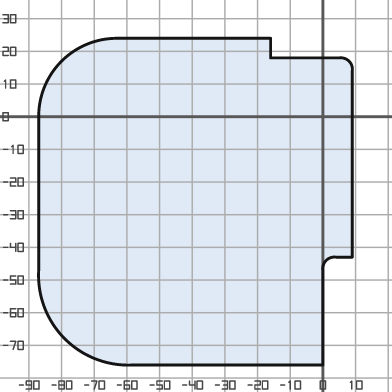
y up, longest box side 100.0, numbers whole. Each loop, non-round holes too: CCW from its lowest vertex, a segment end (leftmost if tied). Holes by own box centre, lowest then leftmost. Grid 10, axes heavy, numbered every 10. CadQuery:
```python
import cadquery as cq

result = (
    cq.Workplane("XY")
    .moveTo(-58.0, -76.0)
    .lineTo(0.0, -76.0)
    .lineTo(0.0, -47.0)
    .threePointArc((1.0, -44.0), (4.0, -43.0))
    .lineTo(9.0, -43.0)
    .lineTo(9.0, 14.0)
    .threePointArc((8.0, 17.0), (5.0, 18.0))
    .lineTo(-16.0, 18.0)
    .lineTo(-16.0, 24.0)
    .lineTo(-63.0, 24.0)
    .threePointArc((-80.0, 17.0), (-87.0, 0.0))
    .lineTo(-87.0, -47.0)
    .threePointArc((-79.0, -68.0), (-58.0, -76.0))
    .close()
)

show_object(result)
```